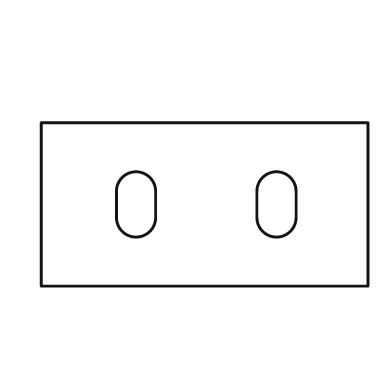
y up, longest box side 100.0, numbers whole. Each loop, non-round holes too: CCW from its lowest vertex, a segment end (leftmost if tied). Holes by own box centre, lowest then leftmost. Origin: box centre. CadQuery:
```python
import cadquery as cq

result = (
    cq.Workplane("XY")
    .moveTo(-50.0, -25.0)
    .lineTo(50.0, -25.0)
    .lineTo(50.0, 25.0)
    .lineTo(-50.0, 25.0)
    .close()
    .moveTo(-27.0, -4.0)
    .threePointArc((-21.0, -10.0), (-15.0, -4.0))
    .lineTo(-15.0, 4.0)
    .threePointArc((-21.0, 10.0), (-27.0, 4.0))
    .close()
    .moveTo(16.0, -4.0)
    .threePointArc((22.0, -10.0), (28.0, -4.0))
    .lineTo(28.0, 4.0)
    .threePointArc((22.0, 10.0), (16.0, 4.0))
    .close()
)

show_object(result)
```